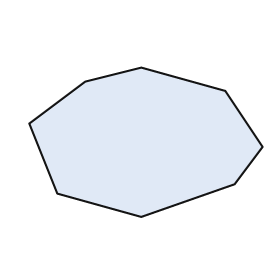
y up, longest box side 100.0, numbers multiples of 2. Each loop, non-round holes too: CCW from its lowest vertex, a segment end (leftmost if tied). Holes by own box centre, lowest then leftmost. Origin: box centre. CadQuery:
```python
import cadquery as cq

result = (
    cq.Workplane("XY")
    .moveTo(-2.0, -32.0)
    .lineTo(38.0, -18.0)
    .lineTo(50.0, -2.0)
    .lineTo(34.0, 22.0)
    .lineTo(-2.0, 32.0)
    .lineTo(-26.0, 26.0)
    .lineTo(-50.0, 8.0)
    .lineTo(-38.0, -22.0)
    .close()
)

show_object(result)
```